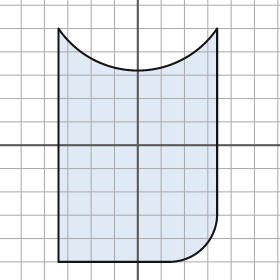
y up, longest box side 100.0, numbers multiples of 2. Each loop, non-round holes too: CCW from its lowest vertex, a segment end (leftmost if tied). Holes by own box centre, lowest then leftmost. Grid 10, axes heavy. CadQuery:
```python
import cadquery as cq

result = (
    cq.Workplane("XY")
    .moveTo(-34.0, -50.0)
    .lineTo(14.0, -50.0)
    .threePointArc((28.0, -44.0), (34.0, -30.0))
    .lineTo(34.0, 50.0)
    .threePointArc((0.0, 32.0), (-34.0, 50.0))
    .close()
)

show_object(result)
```